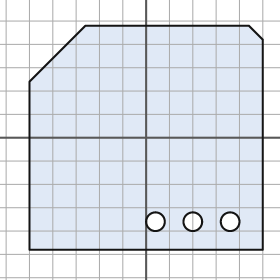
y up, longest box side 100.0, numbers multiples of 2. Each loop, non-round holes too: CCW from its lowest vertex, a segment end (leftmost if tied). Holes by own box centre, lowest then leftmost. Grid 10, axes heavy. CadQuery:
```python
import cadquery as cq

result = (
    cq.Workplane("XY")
    .moveTo(-50.0, -48.0)
    .lineTo(50.0, -48.0)
    .lineTo(50.0, 42.0)
    .lineTo(44.0, 48.0)
    .lineTo(-26.0, 48.0)
    .lineTo(-50.0, 24.0)
    .close()
    .moveTo(4.0, -36.0)
    .circle(4.0)
    .moveTo(20.0, -36.0)
    .circle(4.0)
    .moveTo(36.0, -36.0)
    .circle(4.0)
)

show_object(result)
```